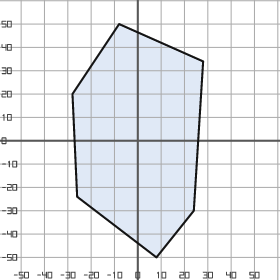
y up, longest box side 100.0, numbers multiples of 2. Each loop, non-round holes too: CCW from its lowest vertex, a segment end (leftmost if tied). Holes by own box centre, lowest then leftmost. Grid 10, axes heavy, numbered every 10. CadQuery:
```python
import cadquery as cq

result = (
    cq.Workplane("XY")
    .moveTo(8.0, -50.0)
    .lineTo(24.0, -30.0)
    .lineTo(28.0, 34.0)
    .lineTo(-8.0, 50.0)
    .lineTo(-28.0, 20.0)
    .lineTo(-26.0, -24.0)
    .close()
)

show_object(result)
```